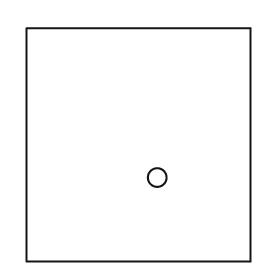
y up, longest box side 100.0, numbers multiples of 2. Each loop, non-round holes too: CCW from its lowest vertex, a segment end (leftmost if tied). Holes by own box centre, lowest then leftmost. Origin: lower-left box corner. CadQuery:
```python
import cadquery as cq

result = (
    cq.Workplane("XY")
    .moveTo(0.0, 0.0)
    .lineTo(96.0, 0.0)
    .lineTo(96.0, 100.0)
    .lineTo(0.0, 100.0)
    .close()
    .moveTo(56.0, 36.0)
    .circle(4.0)
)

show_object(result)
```